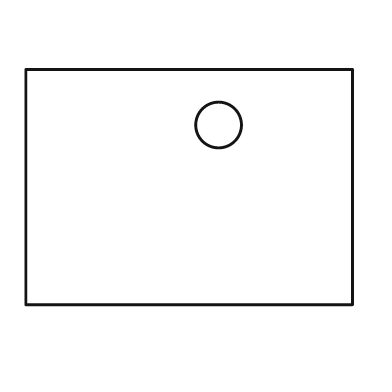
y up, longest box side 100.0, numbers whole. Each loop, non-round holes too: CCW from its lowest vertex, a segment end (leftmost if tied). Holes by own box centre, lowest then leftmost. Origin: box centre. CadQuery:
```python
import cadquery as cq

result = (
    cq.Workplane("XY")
    .moveTo(-50.0, -36.0)
    .lineTo(50.0, -36.0)
    .lineTo(50.0, 36.0)
    .lineTo(-50.0, 36.0)
    .close()
    .moveTo(9.0, 19.0)
    .circle(7.0)
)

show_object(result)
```